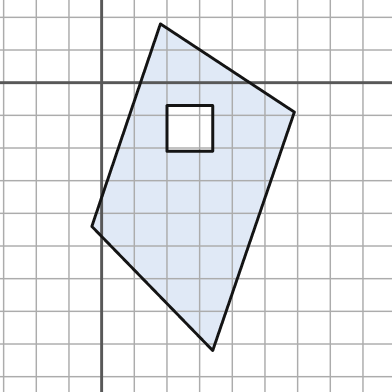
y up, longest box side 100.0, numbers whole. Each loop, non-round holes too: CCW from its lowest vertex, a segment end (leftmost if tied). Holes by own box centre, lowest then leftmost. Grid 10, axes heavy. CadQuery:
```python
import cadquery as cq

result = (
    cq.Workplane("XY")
    .moveTo(34.0, -82.0)
    .lineTo(59.0, -9.0)
    .lineTo(18.0, 18.0)
    .lineTo(-3.0, -44.0)
    .close()
    .moveTo(20.0, -21.0)
    .lineTo(34.0, -21.0)
    .lineTo(34.0, -7.0)
    .lineTo(20.0, -7.0)
    .close()
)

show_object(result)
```